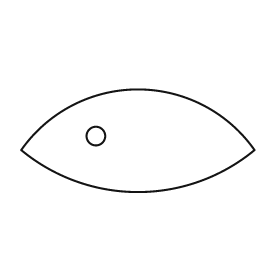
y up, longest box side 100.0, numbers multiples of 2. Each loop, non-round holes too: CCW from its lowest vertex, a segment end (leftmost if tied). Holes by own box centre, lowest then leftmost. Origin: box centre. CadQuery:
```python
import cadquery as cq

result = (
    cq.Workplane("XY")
    .moveTo(-50.0, -4.0)
    .threePointArc((0.0, -22.0), (50.0, -4.0))
    .threePointArc((0.0, 22.0), (-50.0, -4.0))
    .close()
    .moveTo(-18.0, 2.0)
    .circle(4.0)
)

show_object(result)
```